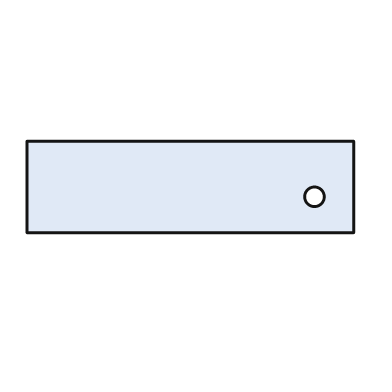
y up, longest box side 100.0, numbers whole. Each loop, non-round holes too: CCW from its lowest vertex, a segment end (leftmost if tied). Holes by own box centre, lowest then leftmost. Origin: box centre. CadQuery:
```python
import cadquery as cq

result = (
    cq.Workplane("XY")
    .moveTo(-50.0, -14.0)
    .lineTo(50.0, -14.0)
    .lineTo(50.0, 14.0)
    .lineTo(-50.0, 14.0)
    .close()
    .moveTo(38.0, -3.0)
    .circle(3.0)
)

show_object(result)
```